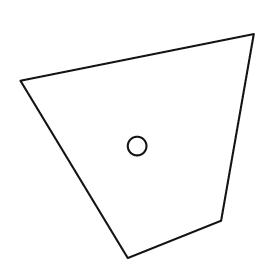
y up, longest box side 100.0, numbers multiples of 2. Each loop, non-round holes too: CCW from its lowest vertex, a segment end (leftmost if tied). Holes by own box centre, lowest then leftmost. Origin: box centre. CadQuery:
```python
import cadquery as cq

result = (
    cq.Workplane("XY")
    .moveTo(-4.0, -48.0)
    .lineTo(36.0, -32.0)
    .lineTo(50.0, 48.0)
    .lineTo(-50.0, 28.0)
    .close()
    .moveTo(0.0, 0.0)
    .circle(4.0)
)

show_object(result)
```